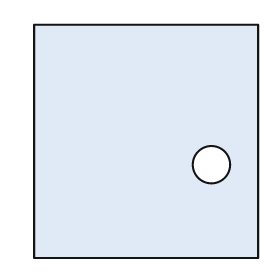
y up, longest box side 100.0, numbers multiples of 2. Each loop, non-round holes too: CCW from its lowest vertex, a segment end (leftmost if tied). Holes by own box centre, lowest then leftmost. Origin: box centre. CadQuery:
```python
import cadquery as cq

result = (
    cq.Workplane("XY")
    .moveTo(-48.0, -50.0)
    .lineTo(48.0, -50.0)
    .lineTo(48.0, 50.0)
    .lineTo(-48.0, 50.0)
    .close()
    .moveTo(28.0, -10.0)
    .circle(8.0)
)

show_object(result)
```